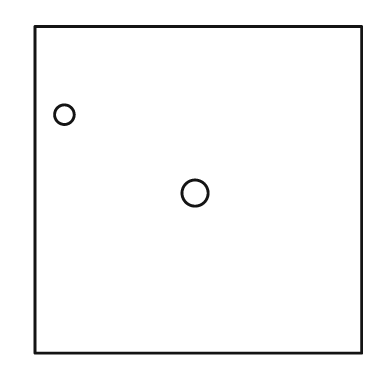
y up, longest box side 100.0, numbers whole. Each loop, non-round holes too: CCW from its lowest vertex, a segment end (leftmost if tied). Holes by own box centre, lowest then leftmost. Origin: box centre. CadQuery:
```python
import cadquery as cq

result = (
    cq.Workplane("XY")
    .moveTo(-50.0, -50.0)
    .lineTo(50.0, -50.0)
    .lineTo(50.0, 50.0)
    .lineTo(-50.0, 50.0)
    .close()
    .moveTo(-1.0, -1.0)
    .circle(4.0)
    .moveTo(-41.0, 23.0)
    .circle(3.0)
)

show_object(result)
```